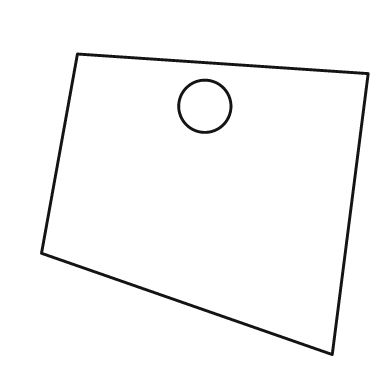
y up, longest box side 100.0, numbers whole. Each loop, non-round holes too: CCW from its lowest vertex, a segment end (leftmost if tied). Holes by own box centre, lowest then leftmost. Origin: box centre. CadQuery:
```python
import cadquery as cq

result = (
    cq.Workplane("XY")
    .moveTo(39.0, -46.0)
    .lineTo(50.0, 40.0)
    .lineTo(-39.0, 46.0)
    .lineTo(-50.0, -15.0)
    .close()
    .moveTo(0.0, 30.0)
    .circle(8.0)
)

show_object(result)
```